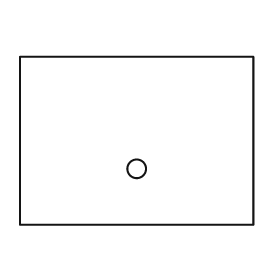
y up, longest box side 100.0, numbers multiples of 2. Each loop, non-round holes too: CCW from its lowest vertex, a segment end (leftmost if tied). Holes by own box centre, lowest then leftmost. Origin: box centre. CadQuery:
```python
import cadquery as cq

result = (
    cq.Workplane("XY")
    .moveTo(-50.0, -36.0)
    .lineTo(50.0, -36.0)
    .lineTo(50.0, 36.0)
    .lineTo(-50.0, 36.0)
    .close()
    .moveTo(0.0, -12.0)
    .circle(4.0)
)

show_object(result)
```